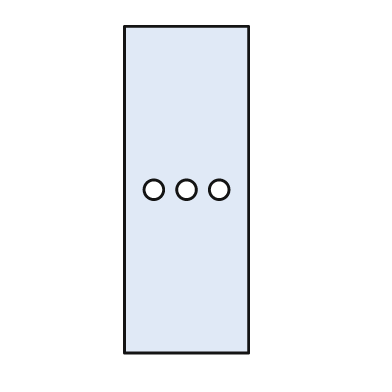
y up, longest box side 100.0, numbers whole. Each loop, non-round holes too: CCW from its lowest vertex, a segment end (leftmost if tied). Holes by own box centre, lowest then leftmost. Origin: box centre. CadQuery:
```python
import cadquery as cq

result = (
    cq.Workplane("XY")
    .moveTo(-19.0, -50.0)
    .lineTo(19.0, -50.0)
    .lineTo(19.0, 50.0)
    .lineTo(-19.0, 50.0)
    .close()
    .moveTo(-10.0, 0.0)
    .circle(3.0)
    .moveTo(0.0, 0.0)
    .circle(3.0)
    .moveTo(10.0, 0.0)
    .circle(3.0)
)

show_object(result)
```